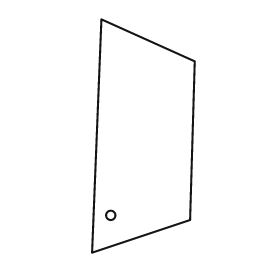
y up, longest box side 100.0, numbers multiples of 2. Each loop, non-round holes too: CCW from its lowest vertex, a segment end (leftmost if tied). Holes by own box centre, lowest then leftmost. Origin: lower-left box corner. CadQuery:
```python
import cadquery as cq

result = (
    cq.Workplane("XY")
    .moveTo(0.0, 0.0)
    .lineTo(42.0, 14.0)
    .lineTo(44.0, 82.0)
    .lineTo(4.0, 100.0)
    .close()
    .moveTo(8.0, 16.0)
    .circle(2.0)
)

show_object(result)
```